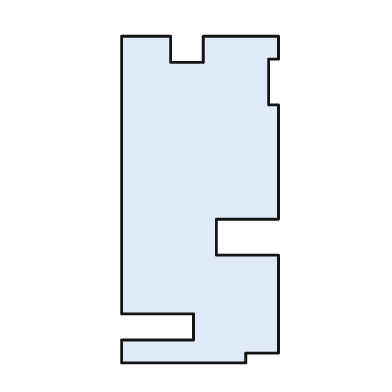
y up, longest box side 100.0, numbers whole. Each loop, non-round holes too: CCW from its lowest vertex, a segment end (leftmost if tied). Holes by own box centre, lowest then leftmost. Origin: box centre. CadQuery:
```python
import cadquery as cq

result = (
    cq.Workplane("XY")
    .moveTo(-24.0, -50.0)
    .lineTo(14.0, -50.0)
    .lineTo(14.0, -47.0)
    .lineTo(24.0, -47.0)
    .lineTo(24.0, -17.0)
    .lineTo(5.0, -17.0)
    .lineTo(5.0, -6.0)
    .lineTo(24.0, -6.0)
    .lineTo(24.0, 29.0)
    .lineTo(21.0, 29.0)
    .lineTo(21.0, 43.0)
    .lineTo(24.0, 43.0)
    .lineTo(24.0, 50.0)
    .lineTo(1.0, 50.0)
    .lineTo(1.0, 42.0)
    .lineTo(-9.0, 42.0)
    .lineTo(-9.0, 50.0)
    .lineTo(-24.0, 50.0)
    .lineTo(-24.0, -35.0)
    .lineTo(-2.0, -35.0)
    .lineTo(-2.0, -43.0)
    .lineTo(-24.0, -43.0)
    .close()
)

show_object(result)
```